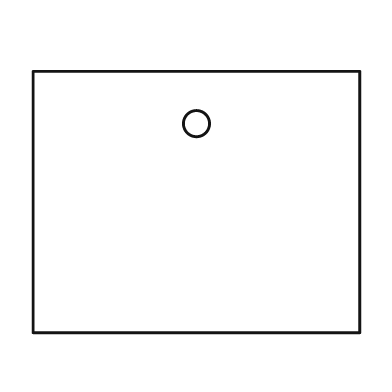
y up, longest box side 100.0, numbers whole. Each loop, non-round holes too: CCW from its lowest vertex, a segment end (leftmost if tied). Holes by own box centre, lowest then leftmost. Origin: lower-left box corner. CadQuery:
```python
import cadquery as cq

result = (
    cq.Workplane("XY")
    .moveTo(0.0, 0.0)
    .lineTo(100.0, 0.0)
    .lineTo(100.0, 80.0)
    .lineTo(0.0, 80.0)
    .close()
    .moveTo(50.0, 64.0)
    .circle(4.0)
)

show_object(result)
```